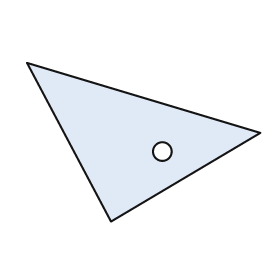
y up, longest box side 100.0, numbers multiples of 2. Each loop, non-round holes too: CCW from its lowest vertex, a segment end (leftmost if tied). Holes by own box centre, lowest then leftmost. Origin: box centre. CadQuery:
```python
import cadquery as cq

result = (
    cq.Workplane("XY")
    .moveTo(-14.0, -34.0)
    .lineTo(50.0, 4.0)
    .lineTo(-50.0, 34.0)
    .close()
    .moveTo(8.0, -4.0)
    .circle(4.0)
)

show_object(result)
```